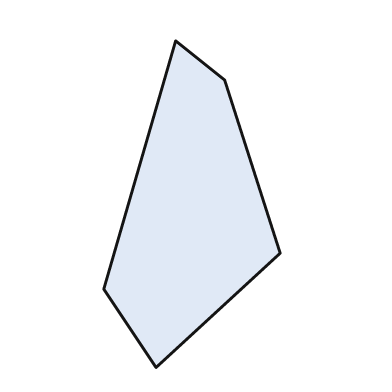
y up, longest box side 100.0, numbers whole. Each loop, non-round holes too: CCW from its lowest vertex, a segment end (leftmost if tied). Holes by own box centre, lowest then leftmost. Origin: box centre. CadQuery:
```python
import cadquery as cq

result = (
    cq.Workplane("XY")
    .moveTo(-11.0, -50.0)
    .lineTo(27.0, -15.0)
    .lineTo(10.0, 38.0)
    .lineTo(-5.0, 50.0)
    .lineTo(-27.0, -26.0)
    .close()
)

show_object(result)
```